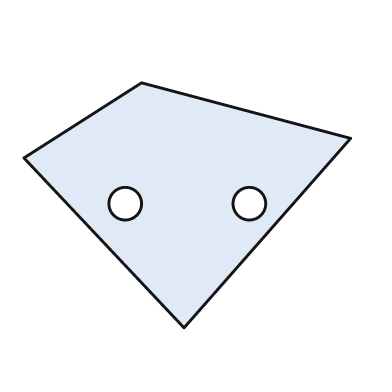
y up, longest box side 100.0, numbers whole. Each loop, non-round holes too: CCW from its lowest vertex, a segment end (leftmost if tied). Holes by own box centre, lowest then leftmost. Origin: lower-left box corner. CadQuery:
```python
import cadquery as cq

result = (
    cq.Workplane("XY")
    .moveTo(49.0, 0.0)
    .lineTo(100.0, 58.0)
    .lineTo(36.0, 75.0)
    .lineTo(0.0, 52.0)
    .close()
    .moveTo(31.0, 38.0)
    .circle(5.0)
    .moveTo(69.0, 38.0)
    .circle(5.0)
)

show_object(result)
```